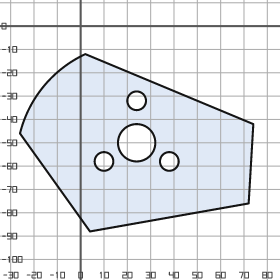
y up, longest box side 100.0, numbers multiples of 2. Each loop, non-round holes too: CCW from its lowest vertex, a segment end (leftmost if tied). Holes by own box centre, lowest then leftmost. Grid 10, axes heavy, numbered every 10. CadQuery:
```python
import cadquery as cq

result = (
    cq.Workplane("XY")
    .moveTo(4.0, -88.0)
    .lineTo(72.0, -76.0)
    .lineTo(74.0, -42.0)
    .lineTo(2.0, -12.0)
    .threePointArc((-16.0, -26.0), (-26.0, -46.0))
    .close()
    .moveTo(10.0, -58.0)
    .circle(4.0)
    .moveTo(38.0, -58.0)
    .circle(4.0)
    .moveTo(24.0, -50.0)
    .circle(8.0)
    .moveTo(24.0, -32.0)
    .circle(4.0)
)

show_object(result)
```